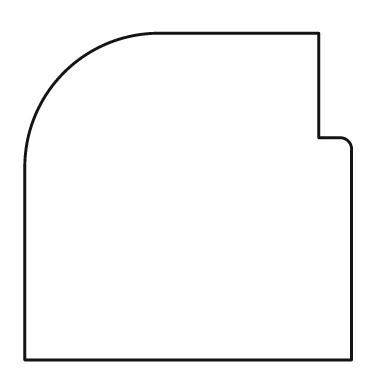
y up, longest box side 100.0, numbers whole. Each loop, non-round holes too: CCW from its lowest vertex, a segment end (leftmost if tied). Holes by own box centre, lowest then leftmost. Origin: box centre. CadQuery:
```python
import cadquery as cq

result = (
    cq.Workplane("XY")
    .moveTo(-50.0, -50.0)
    .lineTo(50.0, -50.0)
    .lineTo(50.0, 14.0)
    .threePointArc((49.0, 17.0), (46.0, 18.0))
    .lineTo(40.0, 18.0)
    .lineTo(40.0, 50.0)
    .lineTo(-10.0, 50.0)
    .threePointArc((-38.0, 38.0), (-50.0, 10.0))
    .close()
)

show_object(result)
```